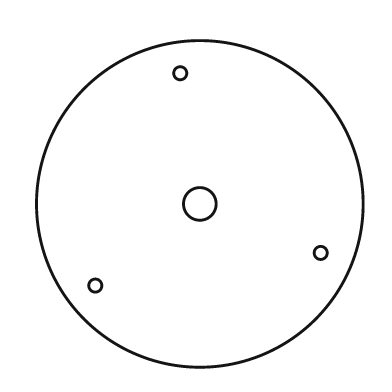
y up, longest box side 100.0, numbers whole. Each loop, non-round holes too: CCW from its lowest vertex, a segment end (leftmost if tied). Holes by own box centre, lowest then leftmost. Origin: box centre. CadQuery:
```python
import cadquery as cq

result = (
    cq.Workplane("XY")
    .moveTo(0.0, 0.0)
    .circle(50.0)
    .moveTo(-32.0, -25.0)
    .circle(2.0)
    .moveTo(37.0, -15.0)
    .circle(2.0)
    .moveTo(0.0, 0.0)
    .circle(5.0)
    .moveTo(-6.0, 40.0)
    .circle(2.0)
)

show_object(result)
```